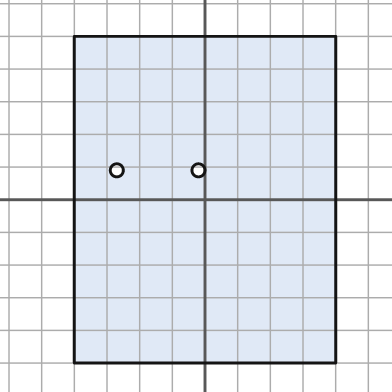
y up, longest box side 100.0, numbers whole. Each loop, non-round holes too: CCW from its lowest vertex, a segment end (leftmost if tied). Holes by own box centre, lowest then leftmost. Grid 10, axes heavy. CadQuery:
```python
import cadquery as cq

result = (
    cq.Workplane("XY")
    .moveTo(-40.0, -50.0)
    .lineTo(40.0, -50.0)
    .lineTo(40.0, 50.0)
    .lineTo(-40.0, 50.0)
    .close()
    .moveTo(-27.0, 9.0)
    .circle(2.0)
    .moveTo(-2.0, 9.0)
    .circle(2.0)
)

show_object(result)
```